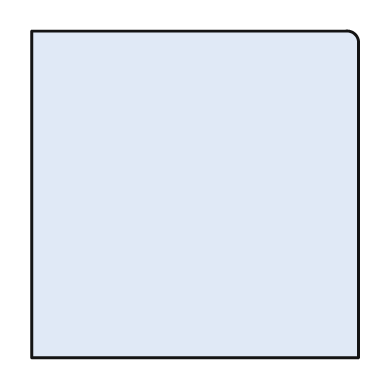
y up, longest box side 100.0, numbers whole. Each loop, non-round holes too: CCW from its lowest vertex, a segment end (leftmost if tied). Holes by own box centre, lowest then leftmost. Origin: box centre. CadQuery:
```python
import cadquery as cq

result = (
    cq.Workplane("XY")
    .moveTo(-50.0, -50.0)
    .lineTo(50.0, -50.0)
    .lineTo(50.0, 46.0)
    .threePointArc((49.0, 49.0), (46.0, 50.0))
    .lineTo(-50.0, 50.0)
    .close()
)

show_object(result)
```